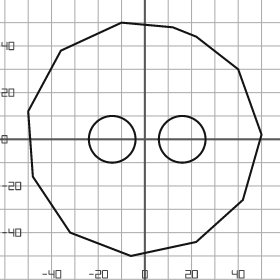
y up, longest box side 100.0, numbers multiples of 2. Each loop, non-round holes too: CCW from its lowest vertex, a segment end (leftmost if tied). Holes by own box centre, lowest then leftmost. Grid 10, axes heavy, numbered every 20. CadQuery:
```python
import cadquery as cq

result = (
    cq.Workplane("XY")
    .moveTo(-6.0, -50.0)
    .lineTo(22.0, -44.0)
    .lineTo(42.0, -26.0)
    .lineTo(50.0, 2.0)
    .lineTo(40.0, 30.0)
    .lineTo(22.0, 44.0)
    .lineTo(12.0, 48.0)
    .lineTo(-10.0, 50.0)
    .lineTo(-36.0, 38.0)
    .lineTo(-50.0, 12.0)
    .lineTo(-48.0, -16.0)
    .lineTo(-32.0, -40.0)
    .close()
    .moveTo(-14.0, 0.0)
    .circle(10.0)
    .moveTo(16.0, 0.0)
    .circle(10.0)
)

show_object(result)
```